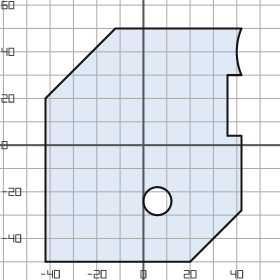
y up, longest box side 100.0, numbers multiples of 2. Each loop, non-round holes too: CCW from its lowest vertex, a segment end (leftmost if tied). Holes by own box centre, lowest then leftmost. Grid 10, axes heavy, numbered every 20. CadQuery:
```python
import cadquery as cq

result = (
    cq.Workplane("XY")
    .moveTo(-42.0, -50.0)
    .lineTo(20.0, -50.0)
    .lineTo(42.0, -28.0)
    .lineTo(42.0, 4.0)
    .lineTo(36.0, 4.0)
    .lineTo(36.0, 30.0)
    .lineTo(42.0, 30.0)
    .threePointArc((40.0, 40.0), (42.0, 50.0))
    .lineTo(-12.0, 50.0)
    .lineTo(-42.0, 20.0)
    .close()
    .moveTo(6.0, -24.0)
    .circle(6.0)
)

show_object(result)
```